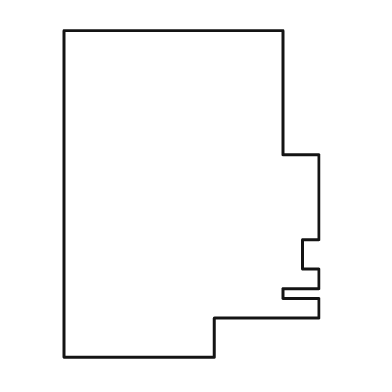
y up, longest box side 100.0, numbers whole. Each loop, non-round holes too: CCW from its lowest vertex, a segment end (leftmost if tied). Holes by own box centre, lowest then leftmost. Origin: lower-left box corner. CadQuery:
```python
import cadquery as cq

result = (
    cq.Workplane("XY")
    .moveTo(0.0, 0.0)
    .lineTo(46.0, 0.0)
    .lineTo(46.0, 12.0)
    .lineTo(78.0, 12.0)
    .lineTo(78.0, 18.0)
    .lineTo(67.0, 18.0)
    .lineTo(67.0, 21.0)
    .lineTo(78.0, 21.0)
    .lineTo(78.0, 27.0)
    .lineTo(73.0, 27.0)
    .lineTo(73.0, 36.0)
    .lineTo(78.0, 36.0)
    .lineTo(78.0, 62.0)
    .lineTo(67.0, 62.0)
    .lineTo(67.0, 100.0)
    .lineTo(0.0, 100.0)
    .close()
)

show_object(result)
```